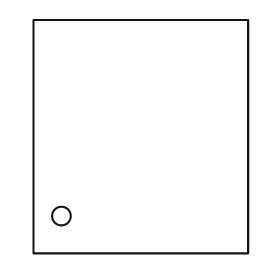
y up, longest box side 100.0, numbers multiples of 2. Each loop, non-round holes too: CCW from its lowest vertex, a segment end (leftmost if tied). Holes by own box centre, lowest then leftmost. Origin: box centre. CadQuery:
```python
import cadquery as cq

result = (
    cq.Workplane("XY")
    .moveTo(-46.0, -50.0)
    .lineTo(46.0, -50.0)
    .lineTo(46.0, 50.0)
    .lineTo(-46.0, 50.0)
    .close()
    .moveTo(-34.0, -34.0)
    .circle(4.0)
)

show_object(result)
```